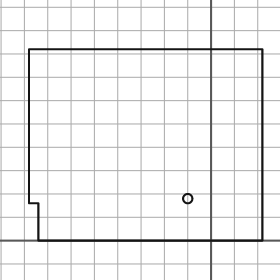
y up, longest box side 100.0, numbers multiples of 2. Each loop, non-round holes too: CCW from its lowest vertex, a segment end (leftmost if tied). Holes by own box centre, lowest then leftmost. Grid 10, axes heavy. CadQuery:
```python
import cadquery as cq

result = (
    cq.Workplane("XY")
    .moveTo(-74.0, 0.0)
    .lineTo(22.0, 0.0)
    .lineTo(22.0, 82.0)
    .lineTo(-78.0, 82.0)
    .lineTo(-78.0, 16.0)
    .lineTo(-74.0, 16.0)
    .close()
    .moveTo(-10.0, 18.0)
    .circle(2.0)
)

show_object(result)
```